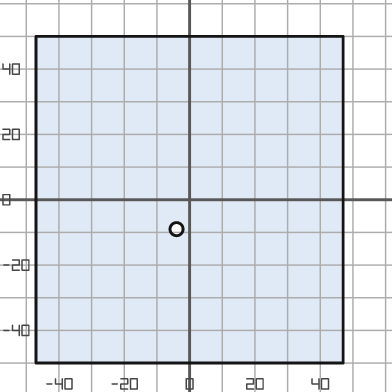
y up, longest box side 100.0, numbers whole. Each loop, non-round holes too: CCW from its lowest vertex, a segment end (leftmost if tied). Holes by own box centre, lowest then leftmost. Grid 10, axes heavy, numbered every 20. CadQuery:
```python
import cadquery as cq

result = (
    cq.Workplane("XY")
    .moveTo(-47.0, -50.0)
    .lineTo(47.0, -50.0)
    .lineTo(47.0, 50.0)
    .lineTo(-47.0, 50.0)
    .close()
    .moveTo(-4.0, -9.0)
    .circle(2.0)
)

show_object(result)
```